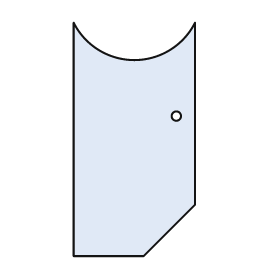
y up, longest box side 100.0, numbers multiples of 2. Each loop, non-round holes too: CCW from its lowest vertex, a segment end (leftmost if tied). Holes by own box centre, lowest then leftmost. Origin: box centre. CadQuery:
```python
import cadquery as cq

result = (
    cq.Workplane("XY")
    .moveTo(-26.0, -50.0)
    .lineTo(4.0, -50.0)
    .lineTo(26.0, -28.0)
    .lineTo(26.0, 50.0)
    .threePointArc((0.0, 34.0), (-26.0, 50.0))
    .close()
    .moveTo(18.0, 10.0)
    .circle(2.0)
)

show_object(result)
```